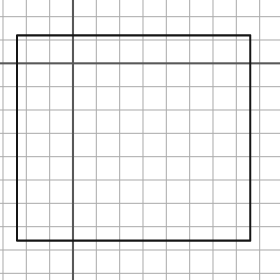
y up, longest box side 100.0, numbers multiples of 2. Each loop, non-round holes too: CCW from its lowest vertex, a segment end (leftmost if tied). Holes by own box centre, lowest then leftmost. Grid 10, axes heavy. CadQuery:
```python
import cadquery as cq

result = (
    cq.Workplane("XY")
    .moveTo(-24.0, -76.0)
    .lineTo(76.0, -76.0)
    .lineTo(76.0, 12.0)
    .lineTo(-24.0, 12.0)
    .close()
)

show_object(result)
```